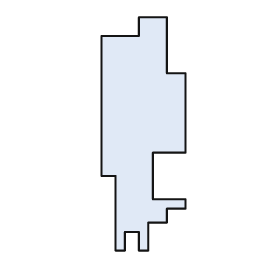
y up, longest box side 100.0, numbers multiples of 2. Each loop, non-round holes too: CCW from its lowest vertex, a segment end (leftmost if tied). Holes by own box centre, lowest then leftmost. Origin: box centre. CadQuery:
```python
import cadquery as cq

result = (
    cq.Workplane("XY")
    .moveTo(-12.0, -50.0)
    .lineTo(-8.0, -50.0)
    .lineTo(-8.0, -42.0)
    .lineTo(-2.0, -42.0)
    .lineTo(-2.0, -50.0)
    .lineTo(2.0, -50.0)
    .lineTo(2.0, -38.0)
    .lineTo(10.0, -38.0)
    .lineTo(10.0, -32.0)
    .lineTo(18.0, -32.0)
    .lineTo(18.0, -28.0)
    .lineTo(4.0, -28.0)
    .lineTo(4.0, -8.0)
    .lineTo(18.0, -8.0)
    .lineTo(18.0, 26.0)
    .lineTo(10.0, 26.0)
    .lineTo(10.0, 50.0)
    .lineTo(-2.0, 50.0)
    .lineTo(-2.0, 42.0)
    .lineTo(-18.0, 42.0)
    .lineTo(-18.0, -18.0)
    .lineTo(-12.0, -18.0)
    .close()
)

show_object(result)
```